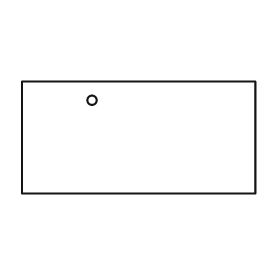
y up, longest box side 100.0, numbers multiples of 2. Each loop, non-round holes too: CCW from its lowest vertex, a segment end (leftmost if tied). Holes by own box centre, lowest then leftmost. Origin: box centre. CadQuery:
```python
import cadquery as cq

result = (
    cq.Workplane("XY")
    .moveTo(-50.0, -24.0)
    .lineTo(50.0, -24.0)
    .lineTo(50.0, 24.0)
    .lineTo(-50.0, 24.0)
    .close()
    .moveTo(-20.0, 16.0)
    .circle(2.0)
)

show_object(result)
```